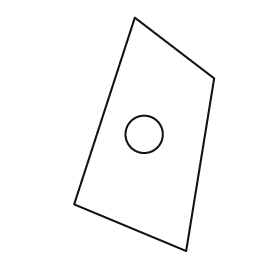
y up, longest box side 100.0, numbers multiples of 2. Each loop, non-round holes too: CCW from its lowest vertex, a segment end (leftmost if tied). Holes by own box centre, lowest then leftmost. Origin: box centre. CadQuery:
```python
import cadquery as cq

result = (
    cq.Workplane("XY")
    .moveTo(18.0, -50.0)
    .lineTo(30.0, 24.0)
    .lineTo(-4.0, 50.0)
    .lineTo(-30.0, -30.0)
    .close()
    .moveTo(0.0, 0.0)
    .circle(8.0)
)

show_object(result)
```